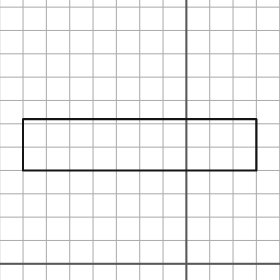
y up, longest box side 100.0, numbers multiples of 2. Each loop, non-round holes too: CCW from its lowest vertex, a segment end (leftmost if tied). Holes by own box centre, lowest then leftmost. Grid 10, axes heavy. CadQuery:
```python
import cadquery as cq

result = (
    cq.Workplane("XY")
    .moveTo(-70.0, 40.0)
    .lineTo(30.0, 40.0)
    .lineTo(30.0, 62.0)
    .lineTo(-70.0, 62.0)
    .close()
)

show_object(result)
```